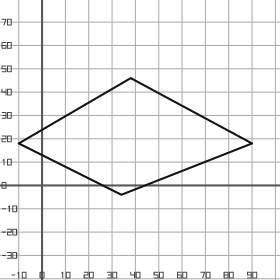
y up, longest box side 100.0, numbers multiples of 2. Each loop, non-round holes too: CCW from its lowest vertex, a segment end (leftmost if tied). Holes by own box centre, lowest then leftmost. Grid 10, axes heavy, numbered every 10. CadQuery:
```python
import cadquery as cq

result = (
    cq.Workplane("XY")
    .moveTo(34.0, -4.0)
    .lineTo(90.0, 18.0)
    .lineTo(38.0, 46.0)
    .lineTo(-10.0, 18.0)
    .close()
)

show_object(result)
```